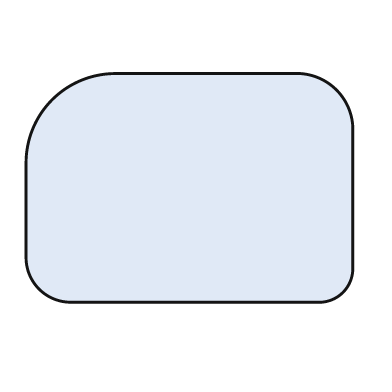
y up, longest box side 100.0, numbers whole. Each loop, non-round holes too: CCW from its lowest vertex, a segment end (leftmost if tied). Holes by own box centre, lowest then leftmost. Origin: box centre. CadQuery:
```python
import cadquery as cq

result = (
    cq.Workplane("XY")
    .moveTo(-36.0, -35.0)
    .lineTo(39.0, -35.0)
    .threePointArc((47.0, -32.0), (50.0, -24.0))
    .lineTo(50.0, 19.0)
    .threePointArc((45.0, 30.0), (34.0, 35.0))
    .lineTo(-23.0, 35.0)
    .threePointArc((-42.0, 27.0), (-50.0, 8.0))
    .lineTo(-50.0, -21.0)
    .threePointArc((-46.0, -31.0), (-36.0, -35.0))
    .close()
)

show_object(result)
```